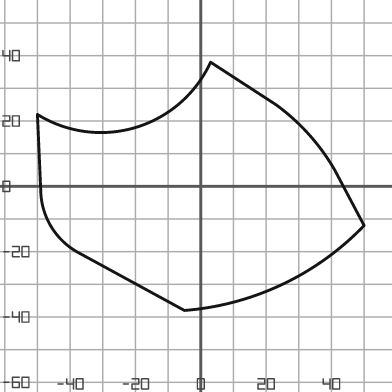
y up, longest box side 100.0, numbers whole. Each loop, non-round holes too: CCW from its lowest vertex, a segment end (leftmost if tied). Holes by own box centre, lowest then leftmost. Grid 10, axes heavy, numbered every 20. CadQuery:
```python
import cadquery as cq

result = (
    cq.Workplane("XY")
    .moveTo(-5.0, -38.0)
    .threePointArc((25.0, -30.0), (50.0, -12.0))
    .lineTo(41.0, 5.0)
    .threePointArc((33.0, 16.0), (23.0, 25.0))
    .lineTo(3.0, 38.0)
    .threePointArc((-20.0, 18.0), (-50.0, 22.0))
    .lineTo(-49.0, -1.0)
    .threePointArc((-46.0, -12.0), (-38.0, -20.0))
    .close()
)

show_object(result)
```